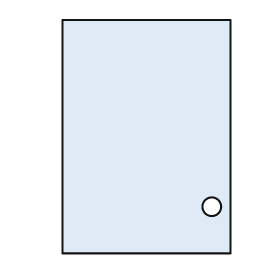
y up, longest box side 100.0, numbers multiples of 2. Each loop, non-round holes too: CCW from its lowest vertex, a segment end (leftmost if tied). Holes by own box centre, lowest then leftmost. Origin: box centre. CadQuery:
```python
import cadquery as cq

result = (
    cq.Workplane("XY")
    .moveTo(-36.0, -50.0)
    .lineTo(36.0, -50.0)
    .lineTo(36.0, 50.0)
    .lineTo(-36.0, 50.0)
    .close()
    .moveTo(28.0, -30.0)
    .circle(4.0)
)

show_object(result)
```